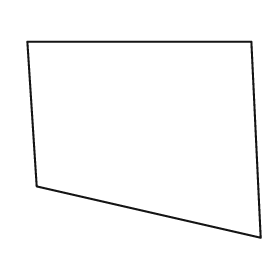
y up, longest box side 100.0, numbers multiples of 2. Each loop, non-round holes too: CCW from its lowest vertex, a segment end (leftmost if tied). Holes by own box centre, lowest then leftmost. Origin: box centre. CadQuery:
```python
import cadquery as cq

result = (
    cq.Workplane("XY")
    .moveTo(50.0, -42.0)
    .lineTo(46.0, 42.0)
    .lineTo(-50.0, 42.0)
    .lineTo(-46.0, -20.0)
    .close()
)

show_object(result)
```